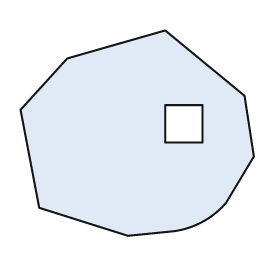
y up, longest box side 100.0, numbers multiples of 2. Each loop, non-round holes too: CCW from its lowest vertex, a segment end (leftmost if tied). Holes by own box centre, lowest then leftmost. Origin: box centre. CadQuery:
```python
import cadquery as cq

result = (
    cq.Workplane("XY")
    .moveTo(-4.0, -44.0)
    .lineTo(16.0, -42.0)
    .threePointArc((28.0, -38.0), (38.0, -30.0))
    .lineTo(50.0, -10.0)
    .lineTo(46.0, 16.0)
    .lineTo(12.0, 44.0)
    .lineTo(-30.0, 32.0)
    .lineTo(-50.0, 10.0)
    .lineTo(-42.0, -32.0)
    .close()
    .moveTo(12.0, -4.0)
    .lineTo(28.0, -4.0)
    .lineTo(28.0, 12.0)
    .lineTo(12.0, 12.0)
    .close()
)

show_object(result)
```